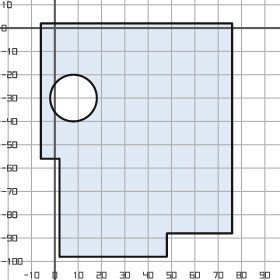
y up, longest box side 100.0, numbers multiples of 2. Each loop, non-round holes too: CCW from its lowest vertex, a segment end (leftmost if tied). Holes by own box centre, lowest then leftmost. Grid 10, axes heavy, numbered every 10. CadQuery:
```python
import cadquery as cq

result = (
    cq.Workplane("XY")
    .moveTo(2.0, -98.0)
    .lineTo(48.0, -98.0)
    .lineTo(48.0, -88.0)
    .lineTo(76.0, -88.0)
    .lineTo(76.0, 2.0)
    .lineTo(-6.0, 2.0)
    .lineTo(-6.0, -56.0)
    .lineTo(2.0, -56.0)
    .close()
    .moveTo(8.0, -30.0)
    .circle(10.0)
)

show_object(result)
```